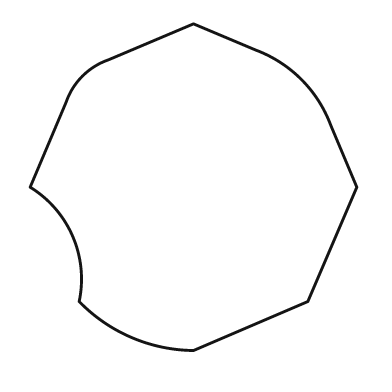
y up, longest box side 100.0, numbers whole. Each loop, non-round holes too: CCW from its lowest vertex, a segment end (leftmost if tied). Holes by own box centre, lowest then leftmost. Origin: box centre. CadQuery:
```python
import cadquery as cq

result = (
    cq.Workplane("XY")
    .moveTo(0.0, -50.0)
    .lineTo(35.0, -35.0)
    .lineTo(50.0, 0.0)
    .lineTo(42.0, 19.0)
    .threePointArc((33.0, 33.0), (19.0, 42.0))
    .lineTo(0.0, 50.0)
    .lineTo(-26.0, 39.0)
    .threePointArc((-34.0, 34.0), (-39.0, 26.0))
    .lineTo(-50.0, 0.0)
    .threePointArc((-37.0, -15.0), (-35.0, -35.0))
    .threePointArc((-19.0, -46.0), (0.0, -50.0))
    .close()
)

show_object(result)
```